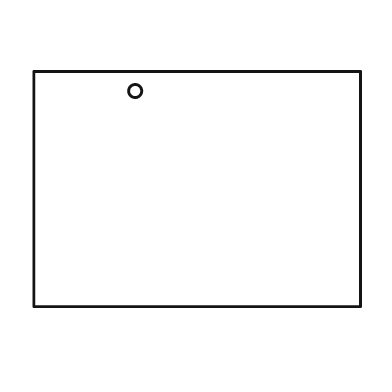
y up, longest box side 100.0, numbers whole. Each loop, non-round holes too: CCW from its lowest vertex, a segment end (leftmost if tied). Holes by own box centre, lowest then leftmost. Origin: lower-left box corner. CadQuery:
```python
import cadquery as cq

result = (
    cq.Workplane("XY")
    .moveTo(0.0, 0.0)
    .lineTo(100.0, 0.0)
    .lineTo(100.0, 72.0)
    .lineTo(0.0, 72.0)
    .close()
    .moveTo(31.0, 66.0)
    .circle(2.0)
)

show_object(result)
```